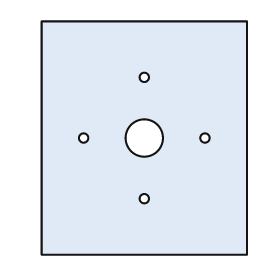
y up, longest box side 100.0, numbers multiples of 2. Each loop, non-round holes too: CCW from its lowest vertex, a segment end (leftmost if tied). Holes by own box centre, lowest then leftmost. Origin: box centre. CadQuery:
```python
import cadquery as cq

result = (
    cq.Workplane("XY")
    .moveTo(-44.0, -50.0)
    .lineTo(44.0, -50.0)
    .lineTo(44.0, 50.0)
    .lineTo(-44.0, 50.0)
    .close()
    .moveTo(0.0, -26.0)
    .circle(2.0)
    .moveTo(-26.0, 0.0)
    .circle(2.0)
    .moveTo(0.0, 0.0)
    .circle(8.0)
    .moveTo(26.0, 0.0)
    .circle(2.0)
    .moveTo(0.0, 26.0)
    .circle(2.0)
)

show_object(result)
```